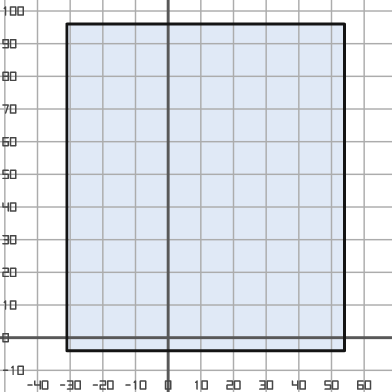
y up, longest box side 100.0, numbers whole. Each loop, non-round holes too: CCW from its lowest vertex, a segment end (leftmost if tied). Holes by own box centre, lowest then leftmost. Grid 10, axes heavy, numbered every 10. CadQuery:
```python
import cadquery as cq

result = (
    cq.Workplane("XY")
    .moveTo(-31.0, -4.0)
    .lineTo(54.0, -4.0)
    .lineTo(54.0, 96.0)
    .lineTo(-31.0, 96.0)
    .close()
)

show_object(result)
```